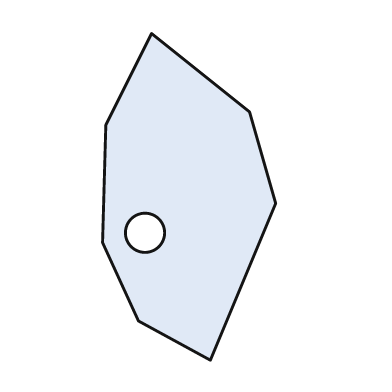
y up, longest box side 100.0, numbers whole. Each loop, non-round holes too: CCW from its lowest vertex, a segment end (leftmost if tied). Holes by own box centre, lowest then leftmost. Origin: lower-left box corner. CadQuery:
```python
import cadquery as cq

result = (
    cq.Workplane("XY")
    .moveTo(33.0, 0.0)
    .lineTo(53.0, 48.0)
    .lineTo(45.0, 76.0)
    .lineTo(15.0, 100.0)
    .lineTo(1.0, 72.0)
    .lineTo(0.0, 36.0)
    .lineTo(11.0, 12.0)
    .close()
    .moveTo(13.0, 39.0)
    .circle(6.0)
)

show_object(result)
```